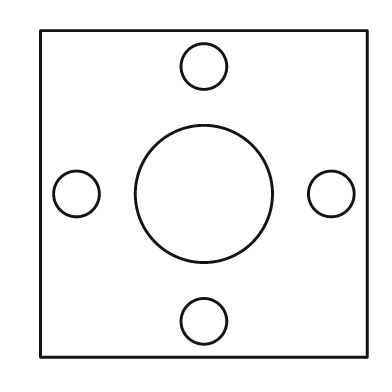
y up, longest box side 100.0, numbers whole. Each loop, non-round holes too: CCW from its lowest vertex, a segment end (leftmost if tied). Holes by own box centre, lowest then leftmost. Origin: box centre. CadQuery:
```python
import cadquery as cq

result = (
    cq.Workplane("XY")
    .moveTo(-50.0, -50.0)
    .lineTo(50.0, -50.0)
    .lineTo(50.0, 50.0)
    .lineTo(-50.0, 50.0)
    .close()
    .moveTo(0.0, -39.0)
    .circle(7.0)
    .moveTo(-39.0, 0.0)
    .circle(7.0)
    .moveTo(0.0, 0.0)
    .circle(21.0)
    .moveTo(39.0, 0.0)
    .circle(7.0)
    .moveTo(0.0, 39.0)
    .circle(7.0)
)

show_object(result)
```